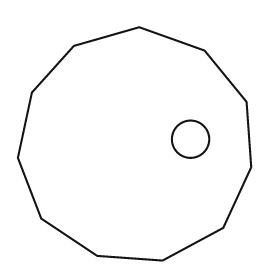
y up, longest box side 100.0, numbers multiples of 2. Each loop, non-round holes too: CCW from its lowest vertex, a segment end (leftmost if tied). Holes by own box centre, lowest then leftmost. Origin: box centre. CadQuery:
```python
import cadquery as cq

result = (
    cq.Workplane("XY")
    .moveTo(12.0, -50.0)
    .lineTo(38.0, -36.0)
    .lineTo(50.0, -10.0)
    .lineTo(48.0, 18.0)
    .lineTo(30.0, 40.0)
    .lineTo(2.0, 50.0)
    .lineTo(-26.0, 42.0)
    .lineTo(-44.0, 22.0)
    .lineTo(-50.0, -6.0)
    .lineTo(-40.0, -32.0)
    .lineTo(-16.0, -48.0)
    .close()
    .moveTo(24.0, 2.0)
    .circle(8.0)
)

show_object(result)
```